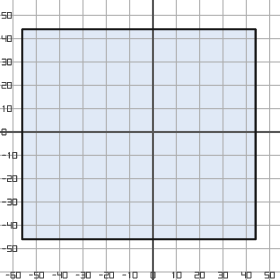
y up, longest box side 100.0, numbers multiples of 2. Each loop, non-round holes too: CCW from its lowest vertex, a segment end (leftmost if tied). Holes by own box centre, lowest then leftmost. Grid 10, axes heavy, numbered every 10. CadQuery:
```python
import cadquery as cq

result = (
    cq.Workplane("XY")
    .moveTo(-56.0, -46.0)
    .lineTo(44.0, -46.0)
    .lineTo(44.0, 44.0)
    .lineTo(-56.0, 44.0)
    .close()
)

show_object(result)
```